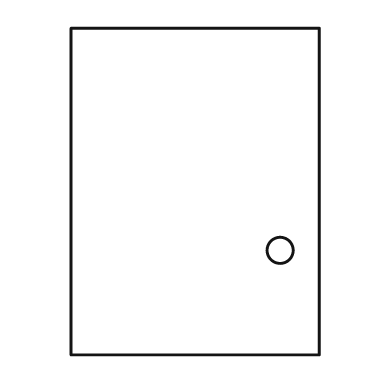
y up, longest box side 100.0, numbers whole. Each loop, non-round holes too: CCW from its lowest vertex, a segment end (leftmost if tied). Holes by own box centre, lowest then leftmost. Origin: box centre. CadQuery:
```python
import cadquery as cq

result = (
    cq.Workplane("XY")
    .moveTo(-38.0, -50.0)
    .lineTo(38.0, -50.0)
    .lineTo(38.0, 50.0)
    .lineTo(-38.0, 50.0)
    .close()
    .moveTo(26.0, -18.0)
    .circle(4.0)
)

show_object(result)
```